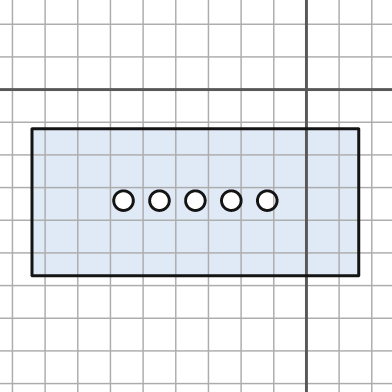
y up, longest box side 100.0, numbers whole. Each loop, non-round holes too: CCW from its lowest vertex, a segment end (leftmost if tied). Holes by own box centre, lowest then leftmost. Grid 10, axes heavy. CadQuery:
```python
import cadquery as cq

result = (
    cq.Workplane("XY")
    .moveTo(-84.0, -57.0)
    .lineTo(16.0, -57.0)
    .lineTo(16.0, -12.0)
    .lineTo(-84.0, -12.0)
    .close()
    .moveTo(-56.0, -34.0)
    .circle(3.0)
    .moveTo(-45.0, -34.0)
    .circle(3.0)
    .moveTo(-34.0, -34.0)
    .circle(3.0)
    .moveTo(-23.0, -34.0)
    .circle(3.0)
    .moveTo(-12.0, -34.0)
    .circle(3.0)
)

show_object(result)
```